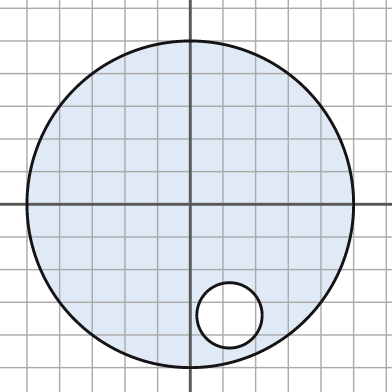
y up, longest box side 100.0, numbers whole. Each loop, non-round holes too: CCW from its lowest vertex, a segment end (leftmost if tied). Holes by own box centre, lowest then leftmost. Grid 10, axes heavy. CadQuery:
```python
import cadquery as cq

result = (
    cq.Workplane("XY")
    .moveTo(0.0, 0.0)
    .circle(50.0)
    .moveTo(12.0, -34.0)
    .circle(10.0)
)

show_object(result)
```